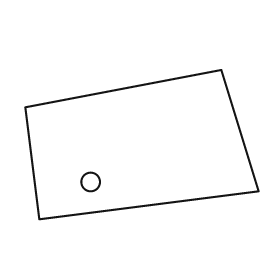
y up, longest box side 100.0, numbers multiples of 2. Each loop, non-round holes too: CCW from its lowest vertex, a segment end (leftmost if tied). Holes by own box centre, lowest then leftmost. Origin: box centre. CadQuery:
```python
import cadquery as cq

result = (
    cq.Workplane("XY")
    .moveTo(-44.0, -32.0)
    .lineTo(50.0, -20.0)
    .lineTo(34.0, 32.0)
    .lineTo(-50.0, 16.0)
    .close()
    .moveTo(-22.0, -16.0)
    .circle(4.0)
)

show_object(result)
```